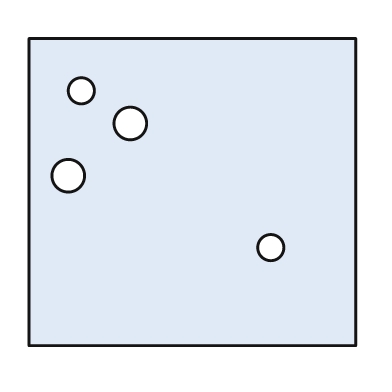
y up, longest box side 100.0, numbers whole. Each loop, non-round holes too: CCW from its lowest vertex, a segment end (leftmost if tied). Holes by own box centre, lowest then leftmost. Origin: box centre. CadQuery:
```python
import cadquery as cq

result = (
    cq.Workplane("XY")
    .moveTo(-50.0, -47.0)
    .lineTo(50.0, -47.0)
    .lineTo(50.0, 47.0)
    .lineTo(-50.0, 47.0)
    .close()
    .moveTo(24.0, -17.0)
    .circle(4.0)
    .moveTo(-38.0, 5.0)
    .circle(5.0)
    .moveTo(-19.0, 21.0)
    .circle(5.0)
    .moveTo(-34.0, 31.0)
    .circle(4.0)
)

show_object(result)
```